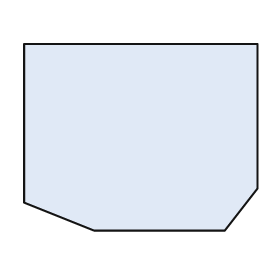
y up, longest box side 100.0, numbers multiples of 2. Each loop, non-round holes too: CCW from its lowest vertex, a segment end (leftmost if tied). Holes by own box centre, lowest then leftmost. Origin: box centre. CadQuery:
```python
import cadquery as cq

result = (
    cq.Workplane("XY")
    .moveTo(-20.0, -40.0)
    .lineTo(36.0, -40.0)
    .lineTo(50.0, -22.0)
    .lineTo(50.0, 40.0)
    .lineTo(-50.0, 40.0)
    .lineTo(-50.0, -28.0)
    .close()
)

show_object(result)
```